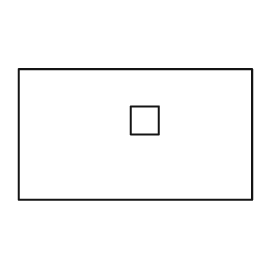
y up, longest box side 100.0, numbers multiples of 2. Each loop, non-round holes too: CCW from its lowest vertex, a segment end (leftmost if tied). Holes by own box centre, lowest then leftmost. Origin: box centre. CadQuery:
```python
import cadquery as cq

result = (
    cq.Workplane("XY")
    .moveTo(-50.0, -28.0)
    .lineTo(50.0, -28.0)
    .lineTo(50.0, 28.0)
    .lineTo(-50.0, 28.0)
    .close()
    .moveTo(-2.0, 0.0)
    .lineTo(10.0, 0.0)
    .lineTo(10.0, 12.0)
    .lineTo(-2.0, 12.0)
    .close()
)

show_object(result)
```